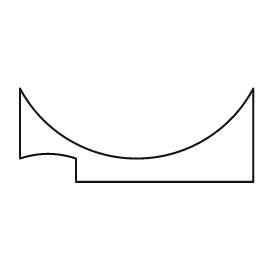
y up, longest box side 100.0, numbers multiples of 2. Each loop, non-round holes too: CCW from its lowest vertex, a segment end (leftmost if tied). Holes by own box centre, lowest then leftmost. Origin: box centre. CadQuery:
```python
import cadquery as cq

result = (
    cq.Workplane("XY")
    .moveTo(-26.0, -20.0)
    .lineTo(50.0, -20.0)
    .lineTo(50.0, 20.0)
    .threePointArc((0.0, -10.0), (-50.0, 20.0))
    .lineTo(-50.0, -10.0)
    .threePointArc((-38.0, -8.0), (-26.0, -10.0))
    .close()
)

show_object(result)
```